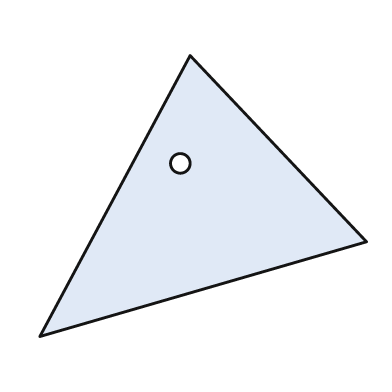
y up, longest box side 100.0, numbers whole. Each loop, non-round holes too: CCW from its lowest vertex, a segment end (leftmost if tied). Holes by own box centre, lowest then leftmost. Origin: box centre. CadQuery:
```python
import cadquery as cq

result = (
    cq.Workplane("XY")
    .moveTo(-50.0, -43.0)
    .lineTo(50.0, -14.0)
    .lineTo(-4.0, 43.0)
    .close()
    .moveTo(-7.0, 10.0)
    .circle(3.0)
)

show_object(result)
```